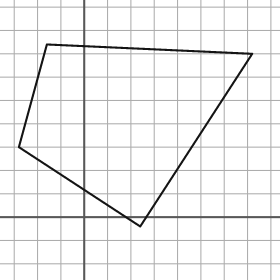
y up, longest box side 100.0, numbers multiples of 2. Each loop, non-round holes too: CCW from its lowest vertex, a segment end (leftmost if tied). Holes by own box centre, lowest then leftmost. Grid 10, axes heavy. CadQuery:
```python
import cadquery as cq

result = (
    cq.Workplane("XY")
    .moveTo(24.0, -4.0)
    .lineTo(72.0, 70.0)
    .lineTo(-16.0, 74.0)
    .lineTo(-28.0, 30.0)
    .close()
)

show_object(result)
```